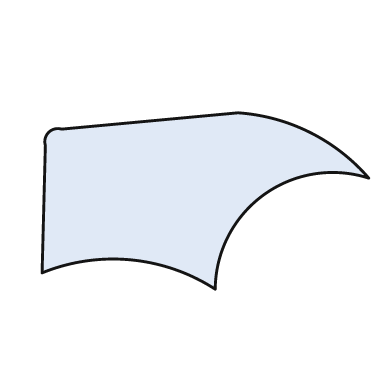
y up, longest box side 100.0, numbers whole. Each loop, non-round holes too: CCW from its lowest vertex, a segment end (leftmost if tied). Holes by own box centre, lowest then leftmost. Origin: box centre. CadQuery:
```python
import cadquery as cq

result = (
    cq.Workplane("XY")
    .moveTo(3.0, -27.0)
    .threePointArc((18.0, 2.0), (50.0, 7.0))
    .threePointArc((32.0, 21.0), (10.0, 27.0))
    .lineTo(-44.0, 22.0)
    .threePointArc((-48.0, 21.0), (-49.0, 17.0))
    .lineTo(-50.0, -22.0)
    .threePointArc((-23.0, -18.0), (3.0, -27.0))
    .close()
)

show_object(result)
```